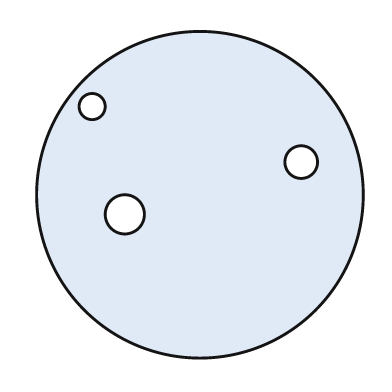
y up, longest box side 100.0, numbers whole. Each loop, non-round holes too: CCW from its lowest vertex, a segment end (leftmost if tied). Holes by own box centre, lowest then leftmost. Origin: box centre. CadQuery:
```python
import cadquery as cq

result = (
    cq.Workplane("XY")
    .moveTo(0.0, 0.0)
    .circle(50.0)
    .moveTo(-23.0, -6.0)
    .circle(6.0)
    .moveTo(31.0, 10.0)
    .circle(5.0)
    .moveTo(-33.0, 27.0)
    .circle(4.0)
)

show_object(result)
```